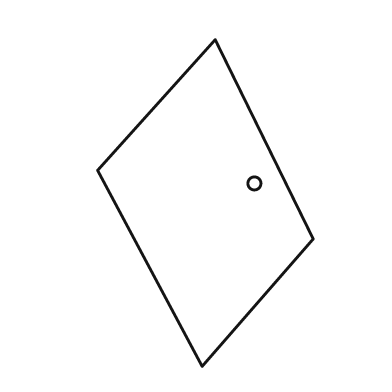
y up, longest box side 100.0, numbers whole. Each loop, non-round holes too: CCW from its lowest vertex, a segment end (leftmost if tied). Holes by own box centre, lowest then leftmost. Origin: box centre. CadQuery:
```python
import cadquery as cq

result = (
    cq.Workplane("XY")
    .moveTo(-1.0, -50.0)
    .lineTo(33.0, -11.0)
    .lineTo(3.0, 50.0)
    .lineTo(-33.0, 10.0)
    .close()
    .moveTo(15.0, 6.0)
    .circle(2.0)
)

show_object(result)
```